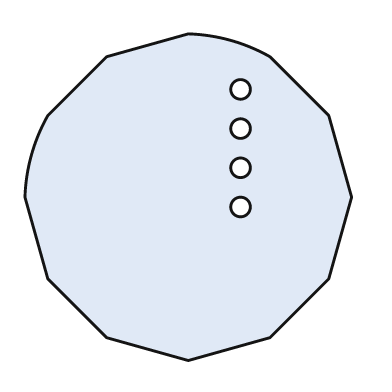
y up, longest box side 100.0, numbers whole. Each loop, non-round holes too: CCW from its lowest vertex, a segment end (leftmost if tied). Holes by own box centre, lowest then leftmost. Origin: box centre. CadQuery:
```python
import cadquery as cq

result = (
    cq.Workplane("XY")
    .moveTo(0.0, -50.0)
    .lineTo(25.0, -43.0)
    .lineTo(43.0, -25.0)
    .lineTo(50.0, 0.0)
    .lineTo(43.0, 25.0)
    .lineTo(25.0, 43.0)
    .threePointArc((13.0, 48.0), (0.0, 50.0))
    .lineTo(-25.0, 43.0)
    .lineTo(-43.0, 25.0)
    .threePointArc((-48.0, 13.0), (-50.0, 0.0))
    .lineTo(-43.0, -25.0)
    .lineTo(-25.0, -43.0)
    .close()
    .moveTo(16.0, -3.0)
    .circle(3.0)
    .moveTo(16.0, 9.0)
    .circle(3.0)
    .moveTo(16.0, 21.0)
    .circle(3.0)
    .moveTo(16.0, 33.0)
    .circle(3.0)
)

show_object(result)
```